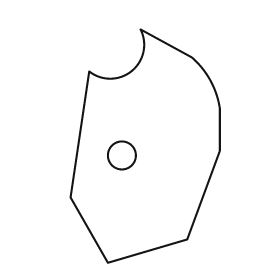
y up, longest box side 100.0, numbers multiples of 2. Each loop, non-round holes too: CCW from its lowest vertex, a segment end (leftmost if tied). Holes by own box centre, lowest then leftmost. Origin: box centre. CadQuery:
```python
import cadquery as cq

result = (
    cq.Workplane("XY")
    .moveTo(-16.0, -50.0)
    .lineTo(18.0, -40.0)
    .lineTo(32.0, -2.0)
    .lineTo(32.0, 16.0)
    .threePointArc((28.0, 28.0), (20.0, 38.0))
    .lineTo(-2.0, 50.0)
    .threePointArc((-6.0, 32.0), (-24.0, 32.0))
    .lineTo(-32.0, -22.0)
    .close()
    .moveTo(-10.0, -4.0)
    .circle(6.0)
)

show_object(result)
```